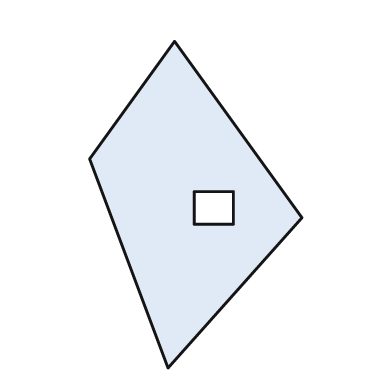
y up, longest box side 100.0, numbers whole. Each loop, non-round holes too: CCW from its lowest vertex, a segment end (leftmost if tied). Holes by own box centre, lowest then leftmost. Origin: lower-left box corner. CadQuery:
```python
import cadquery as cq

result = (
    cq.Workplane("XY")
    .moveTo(24.0, 0.0)
    .lineTo(65.0, 46.0)
    .lineTo(26.0, 100.0)
    .lineTo(0.0, 64.0)
    .close()
    .moveTo(32.0, 44.0)
    .lineTo(44.0, 44.0)
    .lineTo(44.0, 54.0)
    .lineTo(32.0, 54.0)
    .close()
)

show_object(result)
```